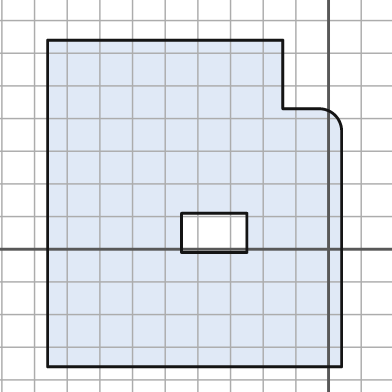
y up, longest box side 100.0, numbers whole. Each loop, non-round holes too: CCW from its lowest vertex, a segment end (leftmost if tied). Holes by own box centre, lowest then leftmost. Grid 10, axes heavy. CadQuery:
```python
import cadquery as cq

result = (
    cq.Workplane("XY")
    .moveTo(-86.0, -36.0)
    .lineTo(4.0, -36.0)
    .lineTo(4.0, 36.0)
    .threePointArc((2.0, 41.0), (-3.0, 43.0))
    .lineTo(-14.0, 43.0)
    .lineTo(-14.0, 64.0)
    .lineTo(-86.0, 64.0)
    .close()
    .moveTo(-45.0, -1.0)
    .lineTo(-25.0, -1.0)
    .lineTo(-25.0, 11.0)
    .lineTo(-45.0, 11.0)
    .close()
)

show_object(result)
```